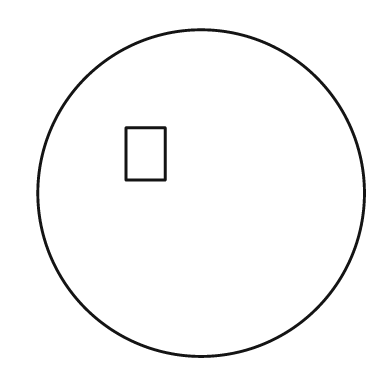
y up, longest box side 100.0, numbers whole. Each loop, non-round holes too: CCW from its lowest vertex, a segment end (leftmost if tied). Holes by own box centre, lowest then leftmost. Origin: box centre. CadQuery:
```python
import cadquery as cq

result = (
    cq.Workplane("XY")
    .moveTo(0.0, 0.0)
    .circle(50.0)
    .moveTo(-23.0, 4.0)
    .lineTo(-11.0, 4.0)
    .lineTo(-11.0, 20.0)
    .lineTo(-23.0, 20.0)
    .close()
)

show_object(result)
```